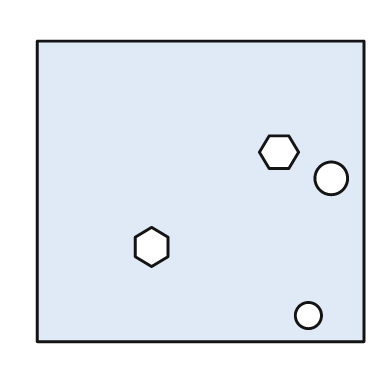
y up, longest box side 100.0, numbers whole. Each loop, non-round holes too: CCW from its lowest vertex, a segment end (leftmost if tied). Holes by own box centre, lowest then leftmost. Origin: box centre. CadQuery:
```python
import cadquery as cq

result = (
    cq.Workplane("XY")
    .moveTo(-50.0, -46.0)
    .lineTo(50.0, -46.0)
    .lineTo(50.0, 46.0)
    .lineTo(-50.0, 46.0)
    .close()
    .moveTo(33.0, -38.0)
    .circle(4.0)
    .moveTo(-15.0, -23.0)
    .lineTo(-10.0, -20.0)
    .lineTo(-10.0, -14.0)
    .lineTo(-15.0, -11.0)
    .lineTo(-20.0, -14.0)
    .lineTo(-20.0, -20.0)
    .close()
    .moveTo(40.0, 4.0)
    .circle(5.0)
    .moveTo(21.0, 7.0)
    .lineTo(27.0, 7.0)
    .lineTo(30.0, 12.0)
    .lineTo(27.0, 17.0)
    .lineTo(21.0, 17.0)
    .lineTo(18.0, 12.0)
    .close()
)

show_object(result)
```